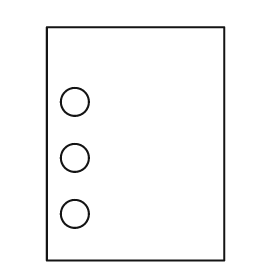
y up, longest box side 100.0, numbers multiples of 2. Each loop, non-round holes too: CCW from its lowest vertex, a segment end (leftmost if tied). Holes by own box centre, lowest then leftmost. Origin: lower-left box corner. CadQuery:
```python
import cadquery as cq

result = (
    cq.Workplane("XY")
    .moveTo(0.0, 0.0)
    .lineTo(76.0, 0.0)
    .lineTo(76.0, 100.0)
    .lineTo(0.0, 100.0)
    .close()
    .moveTo(12.0, 20.0)
    .circle(6.0)
    .moveTo(12.0, 44.0)
    .circle(6.0)
    .moveTo(12.0, 68.0)
    .circle(6.0)
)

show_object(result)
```